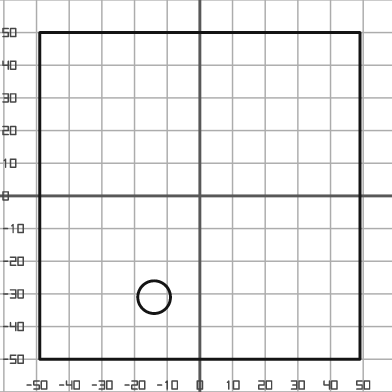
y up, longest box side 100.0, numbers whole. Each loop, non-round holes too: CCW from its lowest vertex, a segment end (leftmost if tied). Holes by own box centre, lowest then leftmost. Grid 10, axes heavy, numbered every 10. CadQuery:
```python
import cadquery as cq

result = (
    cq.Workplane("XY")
    .moveTo(-49.0, -50.0)
    .lineTo(49.0, -50.0)
    .lineTo(49.0, 50.0)
    .lineTo(-49.0, 50.0)
    .close()
    .moveTo(-14.0, -31.0)
    .circle(5.0)
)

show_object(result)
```